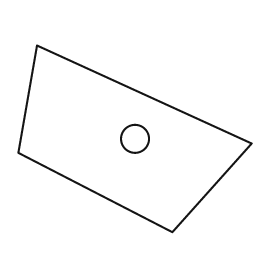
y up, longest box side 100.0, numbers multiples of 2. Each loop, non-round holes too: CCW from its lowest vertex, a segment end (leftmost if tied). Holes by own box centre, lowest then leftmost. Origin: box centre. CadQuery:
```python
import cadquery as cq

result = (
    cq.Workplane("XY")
    .moveTo(16.0, -40.0)
    .lineTo(50.0, -2.0)
    .lineTo(-42.0, 40.0)
    .lineTo(-50.0, -6.0)
    .close()
    .moveTo(0.0, 0.0)
    .circle(6.0)
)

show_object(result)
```